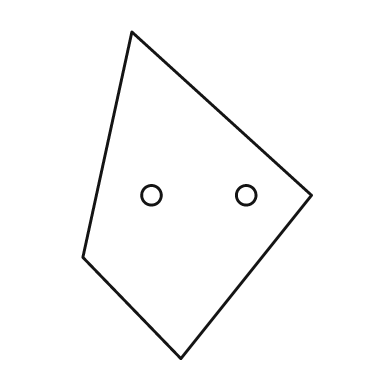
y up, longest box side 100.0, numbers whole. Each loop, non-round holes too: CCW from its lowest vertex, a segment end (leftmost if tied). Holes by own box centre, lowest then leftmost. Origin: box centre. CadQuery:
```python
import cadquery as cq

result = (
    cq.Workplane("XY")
    .moveTo(-5.0, -50.0)
    .lineTo(35.0, 0.0)
    .lineTo(-20.0, 50.0)
    .lineTo(-35.0, -19.0)
    .close()
    .moveTo(-14.0, 0.0)
    .circle(3.0)
    .moveTo(15.0, 0.0)
    .circle(3.0)
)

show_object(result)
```